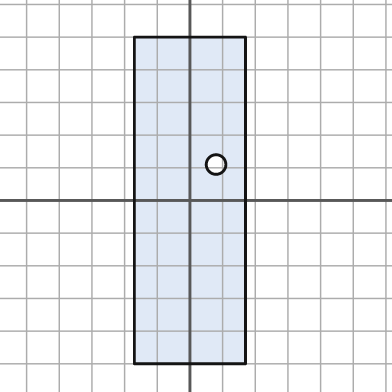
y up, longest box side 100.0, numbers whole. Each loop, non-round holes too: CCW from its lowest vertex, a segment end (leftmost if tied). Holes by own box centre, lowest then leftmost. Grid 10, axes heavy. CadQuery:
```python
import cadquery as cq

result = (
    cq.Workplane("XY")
    .moveTo(-17.0, -50.0)
    .lineTo(17.0, -50.0)
    .lineTo(17.0, 50.0)
    .lineTo(-17.0, 50.0)
    .close()
    .moveTo(8.0, 11.0)
    .circle(3.0)
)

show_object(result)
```